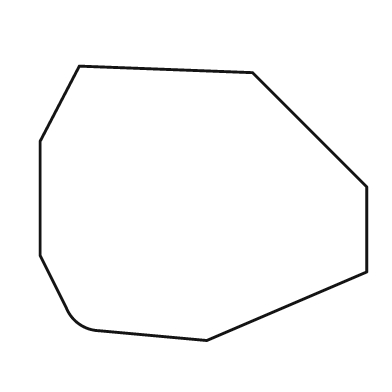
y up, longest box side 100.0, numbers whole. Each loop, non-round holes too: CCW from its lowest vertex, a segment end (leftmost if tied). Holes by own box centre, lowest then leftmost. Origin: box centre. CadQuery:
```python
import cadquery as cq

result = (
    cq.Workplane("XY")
    .moveTo(1.0, -42.0)
    .lineTo(50.0, -21.0)
    .lineTo(50.0, 5.0)
    .lineTo(15.0, 40.0)
    .lineTo(-38.0, 42.0)
    .lineTo(-50.0, 19.0)
    .lineTo(-50.0, -16.0)
    .lineTo(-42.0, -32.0)
    .threePointArc((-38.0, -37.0), (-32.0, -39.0))
    .close()
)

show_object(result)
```